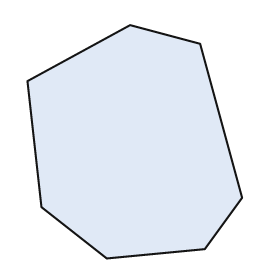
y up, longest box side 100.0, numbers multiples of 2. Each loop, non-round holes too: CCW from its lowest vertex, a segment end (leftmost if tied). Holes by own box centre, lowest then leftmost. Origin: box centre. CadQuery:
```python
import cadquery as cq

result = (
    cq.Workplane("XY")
    .moveTo(-12.0, -50.0)
    .lineTo(30.0, -46.0)
    .lineTo(46.0, -24.0)
    .lineTo(28.0, 42.0)
    .lineTo(-2.0, 50.0)
    .lineTo(-46.0, 26.0)
    .lineTo(-40.0, -28.0)
    .close()
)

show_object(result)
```